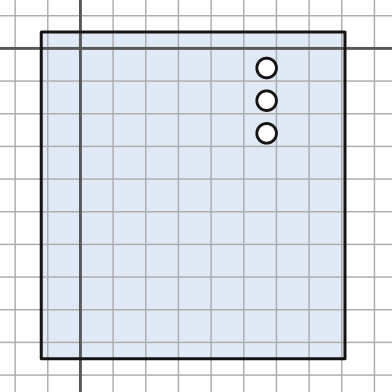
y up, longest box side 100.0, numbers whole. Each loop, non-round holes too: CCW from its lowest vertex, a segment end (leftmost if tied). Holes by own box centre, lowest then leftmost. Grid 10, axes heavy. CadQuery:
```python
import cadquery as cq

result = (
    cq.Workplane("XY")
    .moveTo(-12.0, -95.0)
    .lineTo(81.0, -95.0)
    .lineTo(81.0, 5.0)
    .lineTo(-12.0, 5.0)
    .close()
    .moveTo(57.0, -26.0)
    .circle(3.0)
    .moveTo(57.0, -16.0)
    .circle(3.0)
    .moveTo(57.0, -6.0)
    .circle(3.0)
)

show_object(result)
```